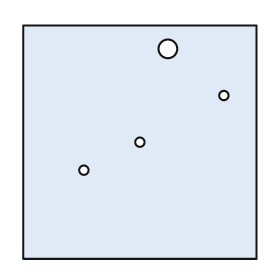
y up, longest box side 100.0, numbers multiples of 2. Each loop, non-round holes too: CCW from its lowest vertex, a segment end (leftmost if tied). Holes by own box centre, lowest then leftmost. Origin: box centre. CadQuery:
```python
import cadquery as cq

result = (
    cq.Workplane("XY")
    .moveTo(-50.0, -50.0)
    .lineTo(50.0, -50.0)
    .lineTo(50.0, 50.0)
    .lineTo(-50.0, 50.0)
    .close()
    .moveTo(-24.0, -12.0)
    .circle(2.0)
    .moveTo(0.0, 0.0)
    .circle(2.0)
    .moveTo(36.0, 20.0)
    .circle(2.0)
    .moveTo(12.0, 40.0)
    .circle(4.0)
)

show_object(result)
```